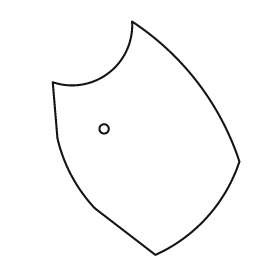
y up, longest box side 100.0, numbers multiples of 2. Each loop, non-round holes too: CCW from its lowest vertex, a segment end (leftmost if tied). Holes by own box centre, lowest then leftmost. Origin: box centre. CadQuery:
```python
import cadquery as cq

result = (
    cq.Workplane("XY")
    .moveTo(4.0, -50.0)
    .threePointArc((26.0, -34.0), (40.0, -10.0))
    .threePointArc((22.0, 24.0), (-6.0, 50.0))
    .threePointArc((-16.0, 28.0), (-40.0, 24.0))
    .lineTo(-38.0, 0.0)
    .threePointArc((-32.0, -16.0), (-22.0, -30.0))
    .close()
    .moveTo(-18.0, 4.0)
    .circle(2.0)
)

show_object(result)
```